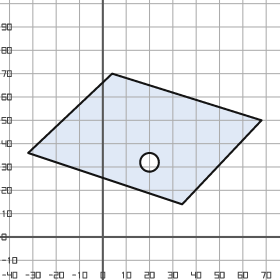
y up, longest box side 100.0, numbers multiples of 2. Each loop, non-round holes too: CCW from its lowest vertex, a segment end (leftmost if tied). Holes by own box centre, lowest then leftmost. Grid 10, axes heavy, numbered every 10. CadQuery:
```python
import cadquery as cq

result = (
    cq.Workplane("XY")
    .moveTo(34.0, 14.0)
    .lineTo(68.0, 50.0)
    .lineTo(4.0, 70.0)
    .lineTo(-32.0, 36.0)
    .close()
    .moveTo(20.0, 32.0)
    .circle(4.0)
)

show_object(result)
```